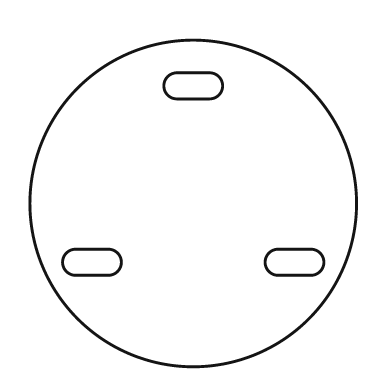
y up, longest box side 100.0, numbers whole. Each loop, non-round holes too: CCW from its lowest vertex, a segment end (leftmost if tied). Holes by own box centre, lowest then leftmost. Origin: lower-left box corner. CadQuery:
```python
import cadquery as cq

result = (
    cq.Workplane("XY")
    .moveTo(50.0, 50.0)
    .circle(50.0)
    .moveTo(14.0, 28.0)
    .lineTo(24.0, 28.0)
    .threePointArc((28.0, 32.0), (24.0, 36.0))
    .lineTo(14.0, 36.0)
    .threePointArc((10.0, 32.0), (14.0, 28.0))
    .close()
    .moveTo(76.0, 28.0)
    .lineTo(86.0, 28.0)
    .threePointArc((90.0, 32.0), (86.0, 36.0))
    .lineTo(76.0, 36.0)
    .threePointArc((72.0, 32.0), (76.0, 28.0))
    .close()
    .moveTo(45.0, 82.0)
    .lineTo(55.0, 82.0)
    .threePointArc((59.0, 86.0), (55.0, 90.0))
    .lineTo(45.0, 90.0)
    .threePointArc((41.0, 86.0), (45.0, 82.0))
    .close()
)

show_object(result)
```